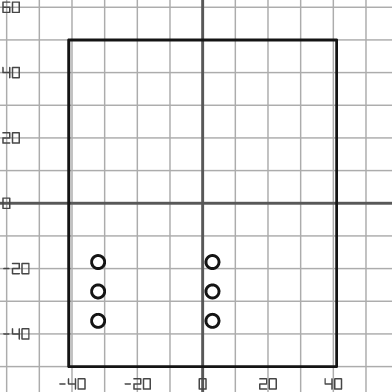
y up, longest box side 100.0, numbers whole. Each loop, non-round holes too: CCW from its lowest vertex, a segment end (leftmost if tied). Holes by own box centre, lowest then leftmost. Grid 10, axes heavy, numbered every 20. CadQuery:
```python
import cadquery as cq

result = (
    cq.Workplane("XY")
    .moveTo(-41.0, -50.0)
    .lineTo(41.0, -50.0)
    .lineTo(41.0, 50.0)
    .lineTo(-41.0, 50.0)
    .close()
    .moveTo(-32.0, -36.0)
    .circle(2.0)
    .moveTo(3.0, -36.0)
    .circle(2.0)
    .moveTo(-32.0, -27.0)
    .circle(2.0)
    .moveTo(3.0, -27.0)
    .circle(2.0)
    .moveTo(-32.0, -18.0)
    .circle(2.0)
    .moveTo(3.0, -18.0)
    .circle(2.0)
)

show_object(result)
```